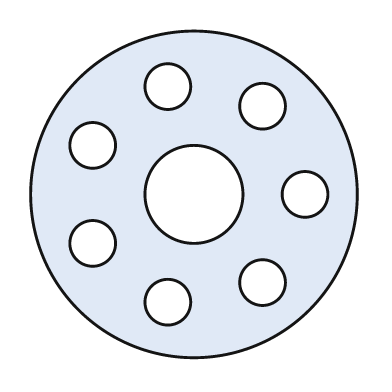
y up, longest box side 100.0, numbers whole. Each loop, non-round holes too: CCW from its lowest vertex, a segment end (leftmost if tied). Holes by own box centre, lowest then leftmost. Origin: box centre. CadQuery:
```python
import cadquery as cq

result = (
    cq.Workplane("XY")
    .moveTo(0.0, 0.0)
    .circle(50.0)
    .moveTo(-8.0, -33.0)
    .circle(7.0)
    .moveTo(21.0, -27.0)
    .circle(7.0)
    .moveTo(-31.0, -15.0)
    .circle(7.0)
    .moveTo(0.0, 0.0)
    .circle(15.0)
    .moveTo(34.0, 0.0)
    .circle(7.0)
    .moveTo(-31.0, 15.0)
    .circle(7.0)
    .moveTo(21.0, 27.0)
    .circle(7.0)
    .moveTo(-8.0, 33.0)
    .circle(7.0)
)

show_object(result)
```